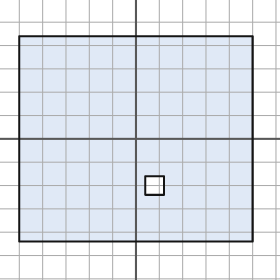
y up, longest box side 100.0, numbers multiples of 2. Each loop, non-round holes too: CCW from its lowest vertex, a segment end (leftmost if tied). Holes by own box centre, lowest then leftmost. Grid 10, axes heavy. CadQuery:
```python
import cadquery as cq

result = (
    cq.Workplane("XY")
    .moveTo(-50.0, -44.0)
    .lineTo(50.0, -44.0)
    .lineTo(50.0, 44.0)
    .lineTo(-50.0, 44.0)
    .close()
    .moveTo(4.0, -24.0)
    .lineTo(12.0, -24.0)
    .lineTo(12.0, -16.0)
    .lineTo(4.0, -16.0)
    .close()
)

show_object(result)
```